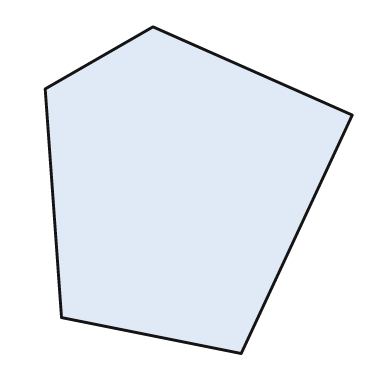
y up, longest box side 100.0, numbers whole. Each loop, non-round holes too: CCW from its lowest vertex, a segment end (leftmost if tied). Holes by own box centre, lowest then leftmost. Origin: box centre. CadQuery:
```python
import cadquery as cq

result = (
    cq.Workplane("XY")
    .moveTo(13.0, -50.0)
    .lineTo(47.0, 23.0)
    .lineTo(-14.0, 50.0)
    .lineTo(-47.0, 31.0)
    .lineTo(-42.0, -39.0)
    .close()
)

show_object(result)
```